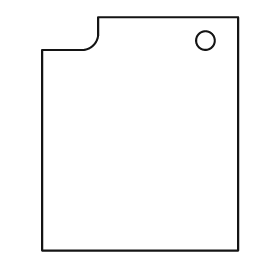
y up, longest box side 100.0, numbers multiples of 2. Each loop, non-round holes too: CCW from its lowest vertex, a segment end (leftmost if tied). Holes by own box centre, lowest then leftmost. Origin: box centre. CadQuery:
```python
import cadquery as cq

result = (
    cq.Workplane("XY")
    .moveTo(-42.0, -50.0)
    .lineTo(42.0, -50.0)
    .lineTo(42.0, 50.0)
    .lineTo(-18.0, 50.0)
    .lineTo(-18.0, 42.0)
    .threePointArc((-20.0, 38.0), (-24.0, 36.0))
    .lineTo(-42.0, 36.0)
    .close()
    .moveTo(28.0, 40.0)
    .circle(4.0)
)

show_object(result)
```